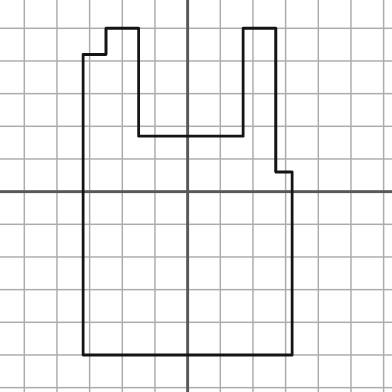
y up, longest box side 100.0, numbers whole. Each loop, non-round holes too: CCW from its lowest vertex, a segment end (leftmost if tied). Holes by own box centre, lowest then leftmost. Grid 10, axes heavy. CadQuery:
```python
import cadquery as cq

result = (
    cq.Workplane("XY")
    .moveTo(-32.0, -50.0)
    .lineTo(32.0, -50.0)
    .lineTo(32.0, 6.0)
    .lineTo(27.0, 6.0)
    .lineTo(27.0, 50.0)
    .lineTo(17.0, 50.0)
    .lineTo(17.0, 17.0)
    .lineTo(-15.0, 17.0)
    .lineTo(-15.0, 50.0)
    .lineTo(-25.0, 50.0)
    .lineTo(-25.0, 42.0)
    .lineTo(-32.0, 42.0)
    .close()
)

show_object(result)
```